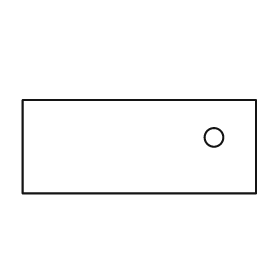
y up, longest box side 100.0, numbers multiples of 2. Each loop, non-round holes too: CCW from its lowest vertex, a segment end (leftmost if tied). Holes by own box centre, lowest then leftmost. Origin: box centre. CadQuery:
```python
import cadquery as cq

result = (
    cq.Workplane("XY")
    .moveTo(-50.0, -20.0)
    .lineTo(50.0, -20.0)
    .lineTo(50.0, 20.0)
    .lineTo(-50.0, 20.0)
    .close()
    .moveTo(32.0, 4.0)
    .circle(4.0)
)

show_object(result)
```